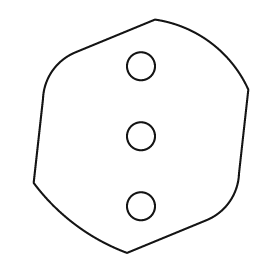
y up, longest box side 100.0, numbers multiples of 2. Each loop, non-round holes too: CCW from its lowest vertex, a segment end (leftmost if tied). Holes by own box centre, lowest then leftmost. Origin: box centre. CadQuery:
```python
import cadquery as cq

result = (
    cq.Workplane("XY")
    .moveTo(-6.0, -50.0)
    .lineTo(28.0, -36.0)
    .threePointArc((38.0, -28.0), (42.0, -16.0))
    .lineTo(46.0, 20.0)
    .threePointArc((30.0, 40.0), (6.0, 50.0))
    .lineTo(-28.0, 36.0)
    .threePointArc((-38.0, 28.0), (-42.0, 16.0))
    .lineTo(-46.0, -20.0)
    .threePointArc((-28.0, -38.0), (-6.0, -50.0))
    .close()
    .moveTo(0.0, -30.0)
    .circle(6.0)
    .moveTo(0.0, 0.0)
    .circle(6.0)
    .moveTo(0.0, 30.0)
    .circle(6.0)
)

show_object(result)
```